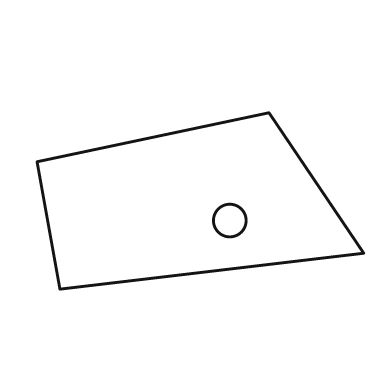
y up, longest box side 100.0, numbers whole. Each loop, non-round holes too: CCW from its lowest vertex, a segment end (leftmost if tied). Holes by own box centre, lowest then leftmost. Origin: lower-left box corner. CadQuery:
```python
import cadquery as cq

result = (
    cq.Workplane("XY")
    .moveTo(7.0, 0.0)
    .lineTo(100.0, 11.0)
    .lineTo(71.0, 54.0)
    .lineTo(0.0, 39.0)
    .close()
    .moveTo(59.0, 21.0)
    .circle(5.0)
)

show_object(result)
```